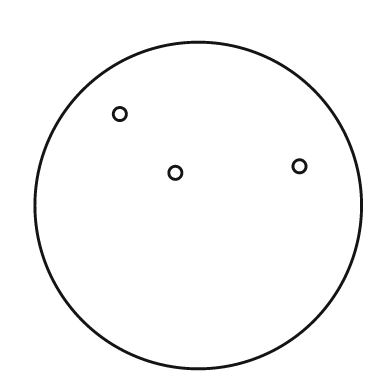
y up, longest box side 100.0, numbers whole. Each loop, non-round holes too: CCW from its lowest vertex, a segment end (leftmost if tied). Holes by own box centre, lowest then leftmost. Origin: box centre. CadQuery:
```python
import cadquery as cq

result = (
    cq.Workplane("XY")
    .moveTo(0.0, 0.0)
    .circle(50.0)
    .moveTo(-7.0, 10.0)
    .circle(2.0)
    .moveTo(31.0, 12.0)
    .circle(2.0)
    .moveTo(-24.0, 28.0)
    .circle(2.0)
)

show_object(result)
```